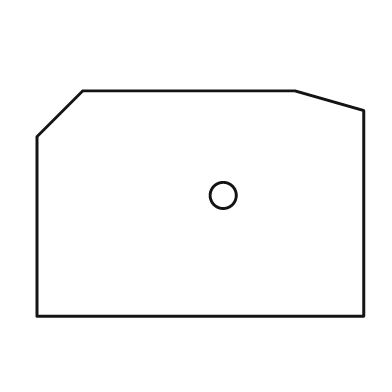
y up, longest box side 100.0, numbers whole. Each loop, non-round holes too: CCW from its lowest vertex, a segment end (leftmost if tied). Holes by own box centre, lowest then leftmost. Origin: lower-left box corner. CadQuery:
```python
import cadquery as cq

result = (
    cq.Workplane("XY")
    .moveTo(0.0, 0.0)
    .lineTo(100.0, 0.0)
    .lineTo(100.0, 63.0)
    .lineTo(79.0, 69.0)
    .lineTo(14.0, 69.0)
    .lineTo(0.0, 55.0)
    .close()
    .moveTo(57.0, 37.0)
    .circle(4.0)
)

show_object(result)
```